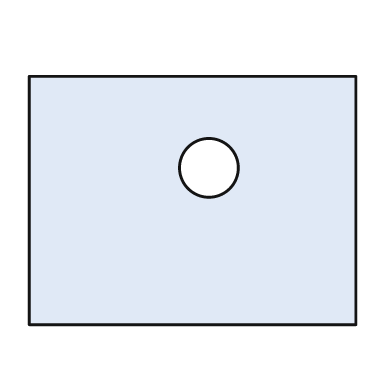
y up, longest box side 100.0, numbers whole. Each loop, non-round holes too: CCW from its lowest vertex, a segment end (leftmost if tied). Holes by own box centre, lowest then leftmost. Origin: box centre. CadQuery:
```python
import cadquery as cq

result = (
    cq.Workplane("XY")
    .moveTo(-50.0, -38.0)
    .lineTo(50.0, -38.0)
    .lineTo(50.0, 38.0)
    .lineTo(-50.0, 38.0)
    .close()
    .moveTo(5.0, 10.0)
    .circle(9.0)
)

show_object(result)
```